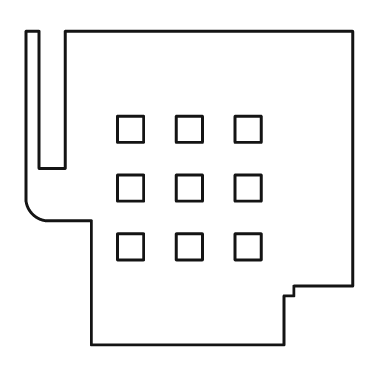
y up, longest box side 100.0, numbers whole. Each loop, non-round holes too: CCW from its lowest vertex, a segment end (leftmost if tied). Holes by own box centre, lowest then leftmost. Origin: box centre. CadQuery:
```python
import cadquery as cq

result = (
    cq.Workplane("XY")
    .moveTo(-30.0, -48.0)
    .lineTo(29.0, -48.0)
    .lineTo(29.0, -33.0)
    .lineTo(32.0, -33.0)
    .lineTo(32.0, -30.0)
    .lineTo(50.0, -30.0)
    .lineTo(50.0, 48.0)
    .lineTo(-38.0, 48.0)
    .lineTo(-38.0, 6.0)
    .lineTo(-46.0, 6.0)
    .lineTo(-46.0, 48.0)
    .lineTo(-50.0, 48.0)
    .lineTo(-50.0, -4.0)
    .threePointArc((-48.0, -8.0), (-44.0, -10.0))
    .lineTo(-30.0, -10.0)
    .close()
    .moveTo(-22.0, -22.0)
    .lineTo(-14.0, -22.0)
    .lineTo(-14.0, -14.0)
    .lineTo(-22.0, -14.0)
    .close()
    .moveTo(-4.0, -22.0)
    .lineTo(4.0, -22.0)
    .lineTo(4.0, -14.0)
    .lineTo(-4.0, -14.0)
    .close()
    .moveTo(14.0, -22.0)
    .lineTo(22.0, -22.0)
    .lineTo(22.0, -14.0)
    .lineTo(14.0, -14.0)
    .close()
    .moveTo(-22.0, -4.0)
    .lineTo(-14.0, -4.0)
    .lineTo(-14.0, 4.0)
    .lineTo(-22.0, 4.0)
    .close()
    .moveTo(-4.0, -4.0)
    .lineTo(4.0, -4.0)
    .lineTo(4.0, 4.0)
    .lineTo(-4.0, 4.0)
    .close()
    .moveTo(14.0, -4.0)
    .lineTo(22.0, -4.0)
    .lineTo(22.0, 4.0)
    .lineTo(14.0, 4.0)
    .close()
    .moveTo(-22.0, 14.0)
    .lineTo(-14.0, 14.0)
    .lineTo(-14.0, 22.0)
    .lineTo(-22.0, 22.0)
    .close()
    .moveTo(-4.0, 14.0)
    .lineTo(4.0, 14.0)
    .lineTo(4.0, 22.0)
    .lineTo(-4.0, 22.0)
    .close()
    .moveTo(14.0, 14.0)
    .lineTo(22.0, 14.0)
    .lineTo(22.0, 22.0)
    .lineTo(14.0, 22.0)
    .close()
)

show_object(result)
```